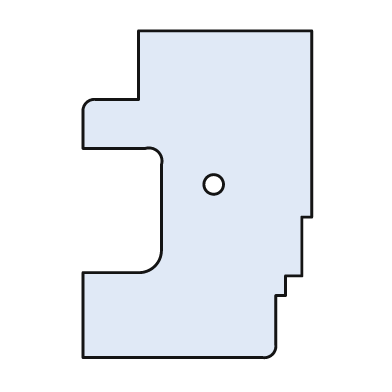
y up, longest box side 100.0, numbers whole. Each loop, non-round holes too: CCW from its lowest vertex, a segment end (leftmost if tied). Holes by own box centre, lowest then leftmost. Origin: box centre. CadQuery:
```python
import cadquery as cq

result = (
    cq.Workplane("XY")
    .moveTo(-35.0, -50.0)
    .lineTo(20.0, -50.0)
    .threePointArc((23.0, -49.0), (24.0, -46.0))
    .lineTo(24.0, -31.0)
    .lineTo(27.0, -31.0)
    .lineTo(27.0, -25.0)
    .lineTo(32.0, -25.0)
    .lineTo(32.0, -7.0)
    .lineTo(35.0, -7.0)
    .lineTo(35.0, 50.0)
    .lineTo(-18.0, 50.0)
    .lineTo(-18.0, 29.0)
    .lineTo(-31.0, 29.0)
    .threePointArc((-34.0, 28.0), (-35.0, 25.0))
    .lineTo(-35.0, 14.0)
    .lineTo(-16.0, 14.0)
    .threePointArc((-12.0, 13.0), (-11.0, 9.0))
    .lineTo(-11.0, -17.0)
    .threePointArc((-13.0, -22.0), (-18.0, -24.0))
    .lineTo(-35.0, -24.0)
    .close()
    .moveTo(5.0, 3.0)
    .circle(3.0)
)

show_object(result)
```